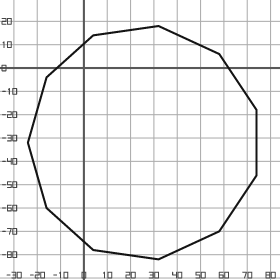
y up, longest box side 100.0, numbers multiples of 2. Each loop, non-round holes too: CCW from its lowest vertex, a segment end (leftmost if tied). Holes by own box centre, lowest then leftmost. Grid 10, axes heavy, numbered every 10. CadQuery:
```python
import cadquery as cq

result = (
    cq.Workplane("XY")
    .moveTo(32.0, -82.0)
    .lineTo(58.0, -70.0)
    .lineTo(74.0, -46.0)
    .lineTo(74.0, -18.0)
    .lineTo(58.0, 6.0)
    .lineTo(32.0, 18.0)
    .lineTo(4.0, 14.0)
    .lineTo(-16.0, -4.0)
    .lineTo(-24.0, -32.0)
    .lineTo(-16.0, -60.0)
    .lineTo(4.0, -78.0)
    .close()
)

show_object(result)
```